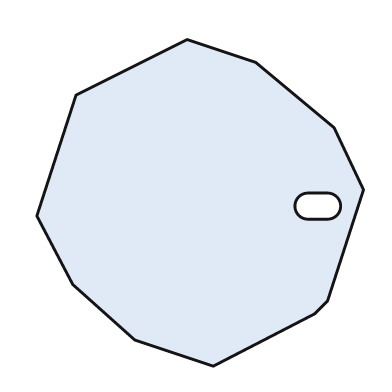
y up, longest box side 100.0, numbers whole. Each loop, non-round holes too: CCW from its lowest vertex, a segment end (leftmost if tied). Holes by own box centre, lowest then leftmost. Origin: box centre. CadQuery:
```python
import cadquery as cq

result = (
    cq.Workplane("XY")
    .moveTo(4.0, -50.0)
    .lineTo(35.0, -34.0)
    .lineTo(39.0, -30.0)
    .lineTo(50.0, 4.0)
    .lineTo(41.0, 23.0)
    .lineTo(17.0, 43.0)
    .lineTo(-4.0, 50.0)
    .lineTo(-38.0, 33.0)
    .lineTo(-50.0, -4.0)
    .lineTo(-39.0, -25.0)
    .lineTo(-20.0, -42.0)
    .close()
    .moveTo(33.0, -5.0)
    .lineTo(39.0, -5.0)
    .threePointArc((43.0, -1.0), (39.0, 3.0))
    .lineTo(33.0, 3.0)
    .threePointArc((29.0, -1.0), (33.0, -5.0))
    .close()
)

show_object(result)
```